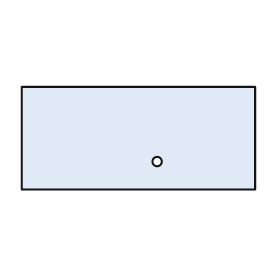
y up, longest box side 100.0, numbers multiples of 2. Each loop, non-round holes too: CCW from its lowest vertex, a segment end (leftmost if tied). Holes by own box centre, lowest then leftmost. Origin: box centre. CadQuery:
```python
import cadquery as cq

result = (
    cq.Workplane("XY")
    .moveTo(-50.0, -22.0)
    .lineTo(50.0, -22.0)
    .lineTo(50.0, 22.0)
    .lineTo(-50.0, 22.0)
    .close()
    .moveTo(8.0, -10.0)
    .circle(2.0)
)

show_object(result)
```